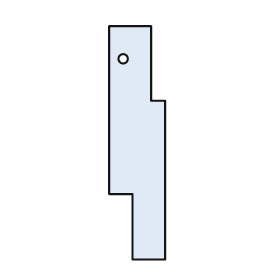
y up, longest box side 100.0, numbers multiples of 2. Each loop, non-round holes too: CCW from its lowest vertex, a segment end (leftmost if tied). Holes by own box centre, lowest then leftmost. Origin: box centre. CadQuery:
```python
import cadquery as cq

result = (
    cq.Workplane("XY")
    .moveTo(-2.0, -50.0)
    .lineTo(12.0, -50.0)
    .lineTo(12.0, 18.0)
    .lineTo(6.0, 18.0)
    .lineTo(6.0, 50.0)
    .lineTo(-12.0, 50.0)
    .lineTo(-12.0, -22.0)
    .lineTo(-2.0, -22.0)
    .close()
    .moveTo(-6.0, 36.0)
    .circle(2.0)
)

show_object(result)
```